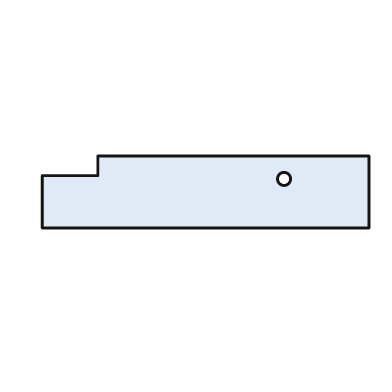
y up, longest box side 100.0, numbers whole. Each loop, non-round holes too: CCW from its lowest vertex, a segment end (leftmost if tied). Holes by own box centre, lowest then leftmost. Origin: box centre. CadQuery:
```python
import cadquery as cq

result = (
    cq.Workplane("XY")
    .moveTo(-50.0, -11.0)
    .lineTo(50.0, -11.0)
    .lineTo(50.0, 11.0)
    .lineTo(-33.0, 11.0)
    .lineTo(-33.0, 5.0)
    .lineTo(-50.0, 5.0)
    .close()
    .moveTo(24.0, 4.0)
    .circle(2.0)
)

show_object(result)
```